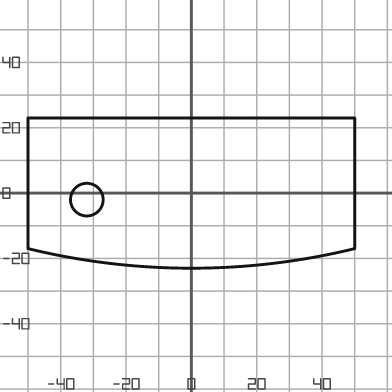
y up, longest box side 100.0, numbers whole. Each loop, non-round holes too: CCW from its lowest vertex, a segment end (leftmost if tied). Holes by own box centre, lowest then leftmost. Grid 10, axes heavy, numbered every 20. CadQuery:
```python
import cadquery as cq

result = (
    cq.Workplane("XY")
    .moveTo(-50.0, -17.0)
    .threePointArc((0.0, -23.0), (50.0, -17.0))
    .lineTo(50.0, 23.0)
    .lineTo(-50.0, 23.0)
    .close()
    .moveTo(-32.0, -2.0)
    .circle(5.0)
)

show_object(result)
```